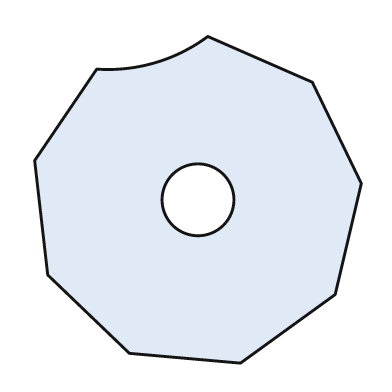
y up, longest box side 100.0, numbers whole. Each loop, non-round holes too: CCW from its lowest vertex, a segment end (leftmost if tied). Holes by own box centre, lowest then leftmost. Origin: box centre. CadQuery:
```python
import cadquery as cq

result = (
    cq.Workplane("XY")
    .moveTo(13.0, -50.0)
    .lineTo(42.0, -29.0)
    .lineTo(50.0, 5.0)
    .lineTo(35.0, 36.0)
    .lineTo(3.0, 50.0)
    .threePointArc((-13.0, 42.0), (-31.0, 40.0))
    .lineTo(-50.0, 12.0)
    .lineTo(-46.0, -23.0)
    .lineTo(-21.0, -47.0)
    .close()
    .moveTo(0.0, 0.0)
    .circle(11.0)
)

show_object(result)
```